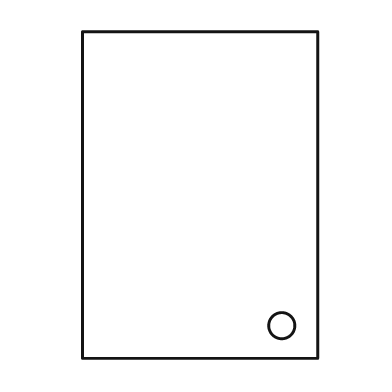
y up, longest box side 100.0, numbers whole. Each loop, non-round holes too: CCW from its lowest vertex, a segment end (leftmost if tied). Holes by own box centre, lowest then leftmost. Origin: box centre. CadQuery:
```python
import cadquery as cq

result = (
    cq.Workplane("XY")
    .moveTo(-36.0, -50.0)
    .lineTo(36.0, -50.0)
    .lineTo(36.0, 50.0)
    .lineTo(-36.0, 50.0)
    .close()
    .moveTo(25.0, -40.0)
    .circle(4.0)
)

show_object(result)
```